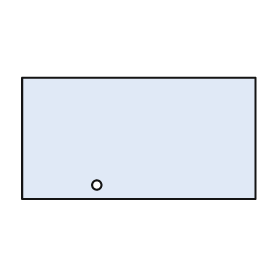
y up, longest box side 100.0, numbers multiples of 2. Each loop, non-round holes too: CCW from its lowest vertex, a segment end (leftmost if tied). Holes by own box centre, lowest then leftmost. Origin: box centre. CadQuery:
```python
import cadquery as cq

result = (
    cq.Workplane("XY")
    .moveTo(-50.0, -26.0)
    .lineTo(50.0, -26.0)
    .lineTo(50.0, 26.0)
    .lineTo(-50.0, 26.0)
    .close()
    .moveTo(-18.0, -20.0)
    .circle(2.0)
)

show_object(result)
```